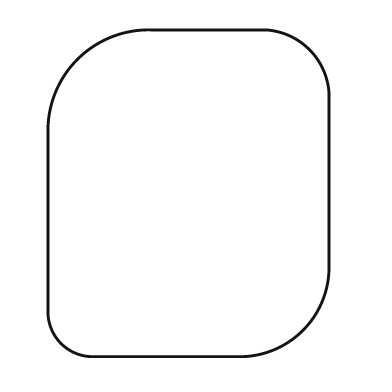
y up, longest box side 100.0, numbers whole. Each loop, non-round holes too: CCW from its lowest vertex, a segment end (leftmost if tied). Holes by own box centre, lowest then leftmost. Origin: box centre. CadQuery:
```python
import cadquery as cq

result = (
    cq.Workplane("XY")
    .moveTo(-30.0, -50.0)
    .lineTo(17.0, -50.0)
    .threePointArc((35.0, -42.0), (43.0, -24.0))
    .lineTo(43.0, 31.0)
    .threePointArc((37.0, 44.0), (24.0, 50.0))
    .lineTo(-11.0, 50.0)
    .threePointArc((-34.0, 41.0), (-43.0, 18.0))
    .lineTo(-43.0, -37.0)
    .threePointArc((-39.0, -46.0), (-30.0, -50.0))
    .close()
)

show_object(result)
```